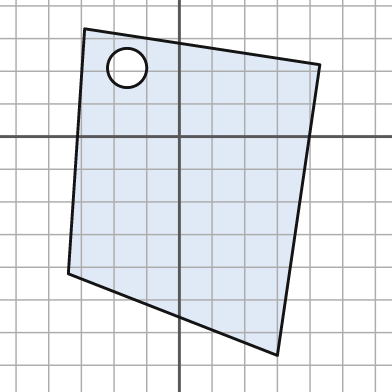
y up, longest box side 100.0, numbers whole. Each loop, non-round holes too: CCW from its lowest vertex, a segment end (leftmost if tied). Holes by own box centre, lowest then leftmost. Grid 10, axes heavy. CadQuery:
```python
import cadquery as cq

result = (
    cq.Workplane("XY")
    .moveTo(30.0, -67.0)
    .lineTo(43.0, 22.0)
    .lineTo(-29.0, 33.0)
    .lineTo(-34.0, -42.0)
    .close()
    .moveTo(-16.0, 21.0)
    .circle(6.0)
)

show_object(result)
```